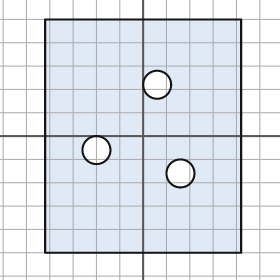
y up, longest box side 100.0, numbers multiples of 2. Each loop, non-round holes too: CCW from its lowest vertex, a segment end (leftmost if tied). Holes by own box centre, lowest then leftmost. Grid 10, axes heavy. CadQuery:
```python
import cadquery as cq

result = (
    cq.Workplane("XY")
    .moveTo(-42.0, -50.0)
    .lineTo(42.0, -50.0)
    .lineTo(42.0, 50.0)
    .lineTo(-42.0, 50.0)
    .close()
    .moveTo(16.0, -16.0)
    .circle(6.0)
    .moveTo(-20.0, -6.0)
    .circle(6.0)
    .moveTo(6.0, 22.0)
    .circle(6.0)
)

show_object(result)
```